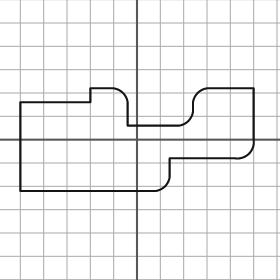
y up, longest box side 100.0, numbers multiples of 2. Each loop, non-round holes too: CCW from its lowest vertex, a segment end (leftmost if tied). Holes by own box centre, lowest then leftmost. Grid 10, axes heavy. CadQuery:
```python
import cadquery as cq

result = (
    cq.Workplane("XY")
    .moveTo(-50.0, -22.0)
    .lineTo(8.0, -22.0)
    .threePointArc((12.0, -20.0), (14.0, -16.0))
    .lineTo(14.0, -8.0)
    .lineTo(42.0, -8.0)
    .threePointArc((48.0, -6.0), (50.0, 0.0))
    .lineTo(50.0, 22.0)
    .lineTo(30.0, 22.0)
    .threePointArc((26.0, 20.0), (24.0, 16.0))
    .lineTo(24.0, 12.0)
    .threePointArc((22.0, 8.0), (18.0, 6.0))
    .lineTo(-4.0, 6.0)
    .lineTo(-4.0, 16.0)
    .threePointArc((-6.0, 20.0), (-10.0, 22.0))
    .lineTo(-20.0, 22.0)
    .lineTo(-20.0, 16.0)
    .lineTo(-50.0, 16.0)
    .close()
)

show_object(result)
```